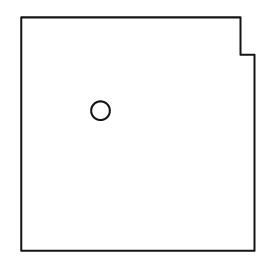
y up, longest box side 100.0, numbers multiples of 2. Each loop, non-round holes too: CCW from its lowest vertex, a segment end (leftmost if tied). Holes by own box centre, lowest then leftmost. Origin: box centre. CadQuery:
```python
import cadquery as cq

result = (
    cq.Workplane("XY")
    .moveTo(-50.0, -50.0)
    .lineTo(50.0, -50.0)
    .lineTo(50.0, 34.0)
    .lineTo(44.0, 34.0)
    .lineTo(44.0, 50.0)
    .lineTo(-50.0, 50.0)
    .close()
    .moveTo(-16.0, 10.0)
    .circle(4.0)
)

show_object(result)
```